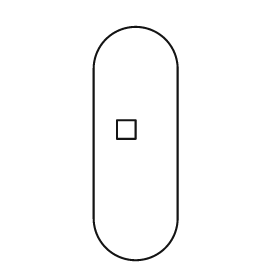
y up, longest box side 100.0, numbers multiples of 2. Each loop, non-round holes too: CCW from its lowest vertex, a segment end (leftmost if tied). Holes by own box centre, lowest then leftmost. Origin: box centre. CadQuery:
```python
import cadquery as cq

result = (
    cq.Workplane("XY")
    .moveTo(-18.0, -32.0)
    .threePointArc((0.0, -50.0), (18.0, -32.0))
    .lineTo(18.0, 32.0)
    .threePointArc((0.0, 50.0), (-18.0, 32.0))
    .close()
    .moveTo(-8.0, 2.0)
    .lineTo(0.0, 2.0)
    .lineTo(0.0, 10.0)
    .lineTo(-8.0, 10.0)
    .close()
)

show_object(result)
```